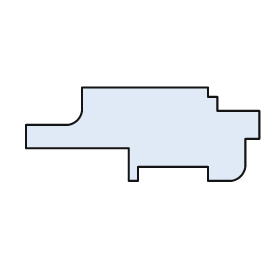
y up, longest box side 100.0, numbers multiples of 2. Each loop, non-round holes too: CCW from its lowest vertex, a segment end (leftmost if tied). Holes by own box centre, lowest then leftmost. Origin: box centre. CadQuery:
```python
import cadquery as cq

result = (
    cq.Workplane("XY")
    .moveTo(-6.0, -20.0)
    .lineTo(-2.0, -20.0)
    .lineTo(-2.0, -14.0)
    .lineTo(28.0, -14.0)
    .lineTo(28.0, -20.0)
    .lineTo(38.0, -20.0)
    .threePointArc((42.0, -18.0), (44.0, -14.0))
    .lineTo(44.0, -2.0)
    .lineTo(50.0, -2.0)
    .lineTo(50.0, 10.0)
    .lineTo(32.0, 10.0)
    .lineTo(32.0, 16.0)
    .lineTo(28.0, 16.0)
    .lineTo(28.0, 20.0)
    .lineTo(-26.0, 20.0)
    .lineTo(-26.0, 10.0)
    .threePointArc((-28.0, 6.0), (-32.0, 4.0))
    .lineTo(-50.0, 4.0)
    .lineTo(-50.0, -6.0)
    .lineTo(-6.0, -6.0)
    .close()
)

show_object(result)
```